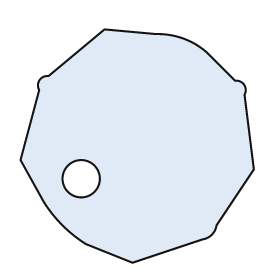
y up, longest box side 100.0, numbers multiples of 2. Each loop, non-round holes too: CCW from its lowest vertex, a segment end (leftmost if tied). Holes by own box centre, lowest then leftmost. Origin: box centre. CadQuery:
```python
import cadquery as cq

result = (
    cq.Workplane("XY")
    .moveTo(-2.0, -50.0)
    .lineTo(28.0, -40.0)
    .threePointArc((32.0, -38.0), (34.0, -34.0))
    .lineTo(50.0, -10.0)
    .lineTo(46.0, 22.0)
    .threePointArc((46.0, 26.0), (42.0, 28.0))
    .lineTo(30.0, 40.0)
    .threePointArc((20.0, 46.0), (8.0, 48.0))
    .lineTo(-14.0, 50.0)
    .lineTo(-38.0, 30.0)
    .threePointArc((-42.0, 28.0), (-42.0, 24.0))
    .lineTo(-50.0, -6.0)
    .lineTo(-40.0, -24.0)
    .threePointArc((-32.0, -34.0), (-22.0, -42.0))
    .close()
    .moveTo(-24.0, -14.0)
    .circle(8.0)
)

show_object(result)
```